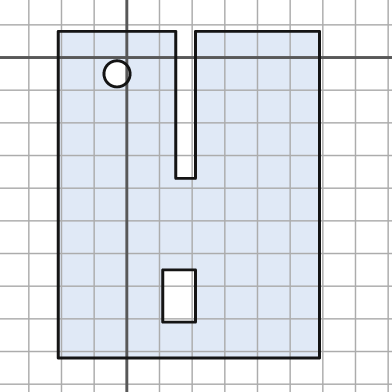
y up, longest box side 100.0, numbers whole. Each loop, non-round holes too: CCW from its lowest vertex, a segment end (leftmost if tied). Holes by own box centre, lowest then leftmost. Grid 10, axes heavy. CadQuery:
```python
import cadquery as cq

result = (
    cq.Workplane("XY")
    .moveTo(-21.0, -92.0)
    .lineTo(59.0, -92.0)
    .lineTo(59.0, 8.0)
    .lineTo(21.0, 8.0)
    .lineTo(21.0, -37.0)
    .lineTo(15.0, -37.0)
    .lineTo(15.0, 8.0)
    .lineTo(-21.0, 8.0)
    .close()
    .moveTo(11.0, -81.0)
    .lineTo(21.0, -81.0)
    .lineTo(21.0, -65.0)
    .lineTo(11.0, -65.0)
    .close()
    .moveTo(-3.0, -5.0)
    .circle(4.0)
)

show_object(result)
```